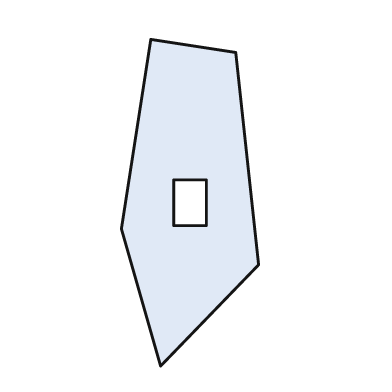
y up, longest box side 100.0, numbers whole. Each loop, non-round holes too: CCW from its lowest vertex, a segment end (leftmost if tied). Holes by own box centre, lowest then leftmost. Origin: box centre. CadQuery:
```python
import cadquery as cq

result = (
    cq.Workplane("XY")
    .moveTo(-9.0, -50.0)
    .lineTo(21.0, -19.0)
    .lineTo(14.0, 46.0)
    .lineTo(-12.0, 50.0)
    .lineTo(-21.0, -8.0)
    .close()
    .moveTo(-5.0, -7.0)
    .lineTo(5.0, -7.0)
    .lineTo(5.0, 7.0)
    .lineTo(-5.0, 7.0)
    .close()
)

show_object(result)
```